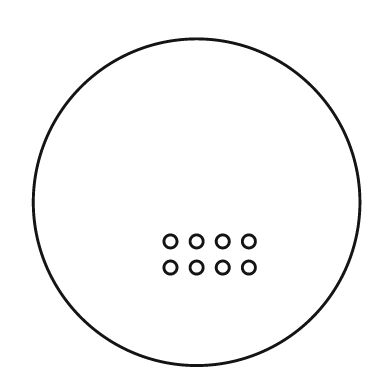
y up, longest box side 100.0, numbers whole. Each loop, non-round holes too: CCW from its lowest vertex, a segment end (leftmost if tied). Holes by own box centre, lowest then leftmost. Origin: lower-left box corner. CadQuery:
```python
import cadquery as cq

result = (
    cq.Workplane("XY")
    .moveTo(50.0, 50.0)
    .circle(50.0)
    .moveTo(42.0, 30.0)
    .circle(2.0)
    .moveTo(50.0, 30.0)
    .circle(2.0)
    .moveTo(58.0, 30.0)
    .circle(2.0)
    .moveTo(66.0, 30.0)
    .circle(2.0)
    .moveTo(42.0, 38.0)
    .circle(2.0)
    .moveTo(50.0, 38.0)
    .circle(2.0)
    .moveTo(58.0, 38.0)
    .circle(2.0)
    .moveTo(66.0, 38.0)
    .circle(2.0)
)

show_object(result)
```